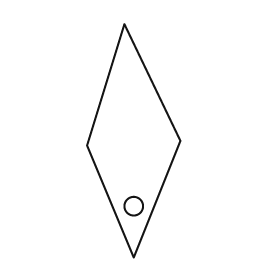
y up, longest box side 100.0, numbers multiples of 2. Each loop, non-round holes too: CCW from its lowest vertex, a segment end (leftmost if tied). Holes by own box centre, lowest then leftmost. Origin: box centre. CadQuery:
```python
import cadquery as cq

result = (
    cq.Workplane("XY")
    .moveTo(0.0, -50.0)
    .lineTo(20.0, 0.0)
    .lineTo(-4.0, 50.0)
    .lineTo(-20.0, -2.0)
    .close()
    .moveTo(0.0, -28.0)
    .circle(4.0)
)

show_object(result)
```